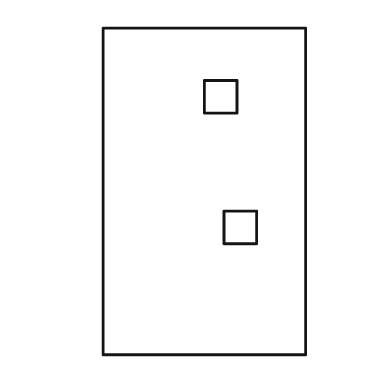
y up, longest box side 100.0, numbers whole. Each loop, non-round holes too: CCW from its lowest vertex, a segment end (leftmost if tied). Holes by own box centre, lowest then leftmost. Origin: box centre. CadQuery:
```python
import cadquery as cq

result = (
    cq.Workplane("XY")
    .moveTo(-31.0, -50.0)
    .lineTo(31.0, -50.0)
    .lineTo(31.0, 50.0)
    .lineTo(-31.0, 50.0)
    .close()
    .moveTo(6.0, -16.0)
    .lineTo(16.0, -16.0)
    .lineTo(16.0, -6.0)
    .lineTo(6.0, -6.0)
    .close()
    .moveTo(0.0, 24.0)
    .lineTo(10.0, 24.0)
    .lineTo(10.0, 34.0)
    .lineTo(0.0, 34.0)
    .close()
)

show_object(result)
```